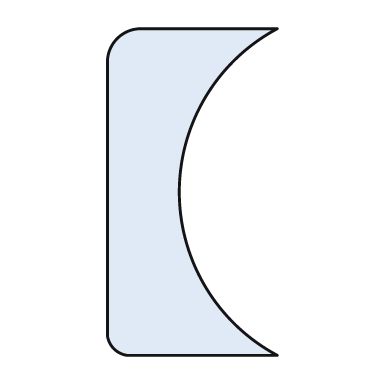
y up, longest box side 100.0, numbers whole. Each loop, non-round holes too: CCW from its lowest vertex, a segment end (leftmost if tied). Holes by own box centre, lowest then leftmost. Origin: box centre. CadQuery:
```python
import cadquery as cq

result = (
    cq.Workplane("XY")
    .moveTo(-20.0, -50.0)
    .lineTo(26.0, -50.0)
    .threePointArc((-4.0, 0.0), (26.0, 50.0))
    .lineTo(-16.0, 50.0)
    .threePointArc((-23.0, 47.0), (-26.0, 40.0))
    .lineTo(-26.0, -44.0)
    .threePointArc((-24.0, -48.0), (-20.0, -50.0))
    .close()
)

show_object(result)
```